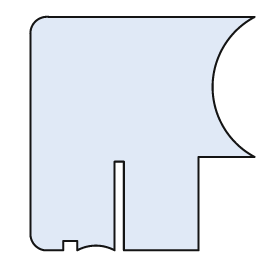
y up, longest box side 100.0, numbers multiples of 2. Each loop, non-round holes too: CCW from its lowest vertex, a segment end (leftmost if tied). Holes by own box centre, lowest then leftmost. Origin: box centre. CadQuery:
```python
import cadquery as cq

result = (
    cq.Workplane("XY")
    .moveTo(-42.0, -50.0)
    .lineTo(-34.0, -50.0)
    .lineTo(-34.0, -46.0)
    .lineTo(-28.0, -46.0)
    .lineTo(-28.0, -50.0)
    .threePointArc((-20.0, -48.0), (-12.0, -50.0))
    .lineTo(-12.0, -12.0)
    .lineTo(-8.0, -12.0)
    .lineTo(-8.0, -50.0)
    .lineTo(24.0, -50.0)
    .lineTo(24.0, -10.0)
    .lineTo(48.0, -10.0)
    .threePointArc((30.0, 20.0), (48.0, 50.0))
    .lineTo(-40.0, 50.0)
    .threePointArc((-46.0, 48.0), (-48.0, 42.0))
    .lineTo(-48.0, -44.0)
    .threePointArc((-46.0, -48.0), (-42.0, -50.0))
    .close()
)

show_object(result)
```